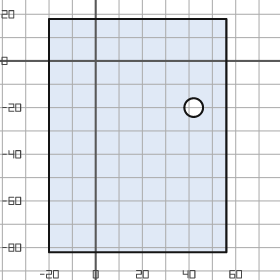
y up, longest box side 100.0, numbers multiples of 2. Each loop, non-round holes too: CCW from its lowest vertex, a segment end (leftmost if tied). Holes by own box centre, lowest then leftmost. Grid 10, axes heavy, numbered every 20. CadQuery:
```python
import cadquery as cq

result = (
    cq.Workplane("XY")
    .moveTo(-20.0, -82.0)
    .lineTo(56.0, -82.0)
    .lineTo(56.0, 18.0)
    .lineTo(-20.0, 18.0)
    .close()
    .moveTo(42.0, -20.0)
    .circle(4.0)
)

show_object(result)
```